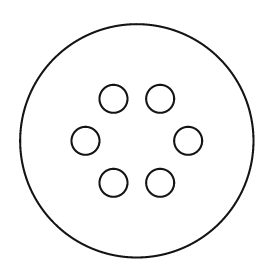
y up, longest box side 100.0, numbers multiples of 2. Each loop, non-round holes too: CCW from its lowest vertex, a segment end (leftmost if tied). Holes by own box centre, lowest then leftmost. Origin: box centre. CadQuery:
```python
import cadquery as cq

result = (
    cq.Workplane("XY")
    .moveTo(0.0, 0.0)
    .circle(50.0)
    .moveTo(-10.0, -18.0)
    .circle(6.0)
    .moveTo(10.0, -18.0)
    .circle(6.0)
    .moveTo(-22.0, 0.0)
    .circle(6.0)
    .moveTo(22.0, 0.0)
    .circle(6.0)
    .moveTo(-10.0, 18.0)
    .circle(6.0)
    .moveTo(10.0, 18.0)
    .circle(6.0)
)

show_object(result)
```